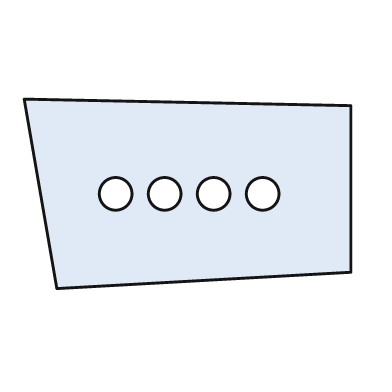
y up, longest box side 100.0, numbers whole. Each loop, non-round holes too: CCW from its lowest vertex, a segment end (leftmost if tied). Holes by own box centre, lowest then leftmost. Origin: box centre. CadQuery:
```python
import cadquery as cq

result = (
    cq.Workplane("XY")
    .moveTo(-40.0, -29.0)
    .lineTo(50.0, -24.0)
    .lineTo(50.0, 27.0)
    .lineTo(-50.0, 29.0)
    .close()
    .moveTo(-22.0, 0.0)
    .circle(5.0)
    .moveTo(-7.0, 0.0)
    .circle(5.0)
    .moveTo(8.0, 0.0)
    .circle(5.0)
    .moveTo(23.0, 0.0)
    .circle(5.0)
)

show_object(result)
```